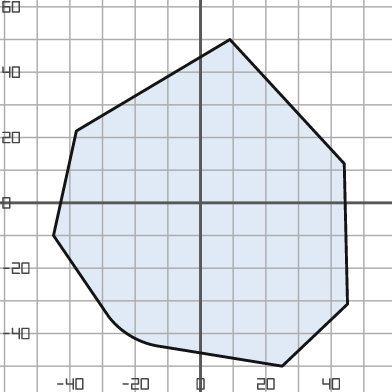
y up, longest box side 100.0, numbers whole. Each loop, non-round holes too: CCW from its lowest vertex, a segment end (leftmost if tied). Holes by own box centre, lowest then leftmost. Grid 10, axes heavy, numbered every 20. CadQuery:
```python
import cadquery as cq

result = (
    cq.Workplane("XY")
    .moveTo(25.0, -50.0)
    .lineTo(45.0, -31.0)
    .lineTo(44.0, 12.0)
    .lineTo(9.0, 50.0)
    .lineTo(-38.0, 22.0)
    .lineTo(-45.0, -10.0)
    .lineTo(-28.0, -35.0)
    .threePointArc((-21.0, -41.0), (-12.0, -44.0))
    .close()
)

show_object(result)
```